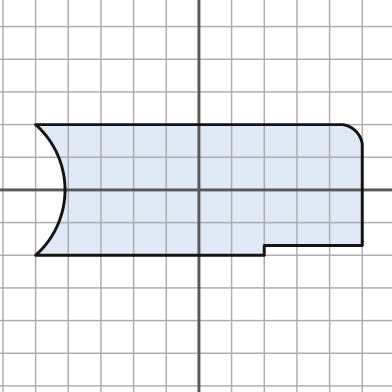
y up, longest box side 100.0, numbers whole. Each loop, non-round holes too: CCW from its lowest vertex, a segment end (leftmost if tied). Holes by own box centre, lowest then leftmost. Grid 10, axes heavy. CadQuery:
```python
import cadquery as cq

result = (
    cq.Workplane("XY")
    .moveTo(-50.0, -20.0)
    .lineTo(20.0, -20.0)
    .lineTo(20.0, -17.0)
    .lineTo(50.0, -17.0)
    .lineTo(50.0, 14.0)
    .threePointArc((48.0, 18.0), (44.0, 20.0))
    .lineTo(-50.0, 20.0)
    .threePointArc((-41.0, 0.0), (-50.0, -20.0))
    .close()
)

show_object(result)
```